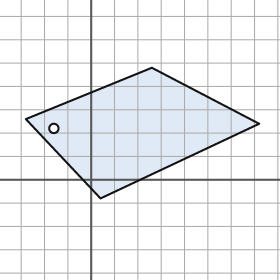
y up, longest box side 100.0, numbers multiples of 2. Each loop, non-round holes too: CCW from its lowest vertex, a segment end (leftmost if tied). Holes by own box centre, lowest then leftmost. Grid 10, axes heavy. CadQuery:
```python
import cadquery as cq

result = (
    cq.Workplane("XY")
    .moveTo(4.0, -8.0)
    .lineTo(72.0, 24.0)
    .lineTo(26.0, 48.0)
    .lineTo(-28.0, 26.0)
    .close()
    .moveTo(-16.0, 22.0)
    .circle(2.0)
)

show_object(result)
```